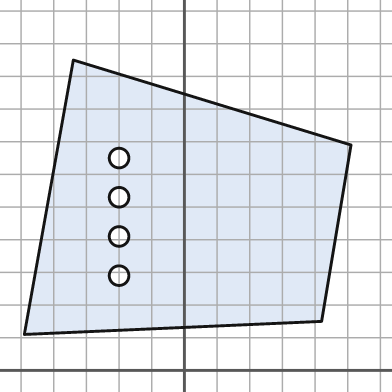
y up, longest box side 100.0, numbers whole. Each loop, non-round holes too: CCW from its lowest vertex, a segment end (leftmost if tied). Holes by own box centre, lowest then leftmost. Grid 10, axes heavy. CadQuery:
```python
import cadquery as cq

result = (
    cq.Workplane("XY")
    .moveTo(-49.0, 11.0)
    .lineTo(42.0, 15.0)
    .lineTo(51.0, 69.0)
    .lineTo(-34.0, 95.0)
    .close()
    .moveTo(-20.0, 29.0)
    .circle(3.0)
    .moveTo(-20.0, 41.0)
    .circle(3.0)
    .moveTo(-20.0, 53.0)
    .circle(3.0)
    .moveTo(-20.0, 65.0)
    .circle(3.0)
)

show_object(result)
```